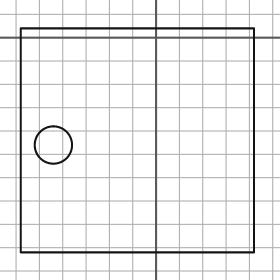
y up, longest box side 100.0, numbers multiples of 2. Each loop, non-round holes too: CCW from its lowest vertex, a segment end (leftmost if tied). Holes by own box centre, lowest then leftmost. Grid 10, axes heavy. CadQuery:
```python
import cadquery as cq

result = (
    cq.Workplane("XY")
    .moveTo(-58.0, -92.0)
    .lineTo(42.0, -92.0)
    .lineTo(42.0, 4.0)
    .lineTo(-58.0, 4.0)
    .close()
    .moveTo(-44.0, -46.0)
    .circle(8.0)
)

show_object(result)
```